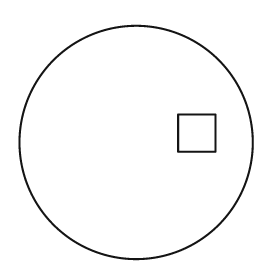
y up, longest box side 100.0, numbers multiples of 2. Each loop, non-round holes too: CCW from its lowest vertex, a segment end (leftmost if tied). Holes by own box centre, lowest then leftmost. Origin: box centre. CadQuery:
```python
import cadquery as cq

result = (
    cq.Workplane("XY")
    .moveTo(0.0, 0.0)
    .circle(50.0)
    .moveTo(18.0, -4.0)
    .lineTo(34.0, -4.0)
    .lineTo(34.0, 12.0)
    .lineTo(18.0, 12.0)
    .close()
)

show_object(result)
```